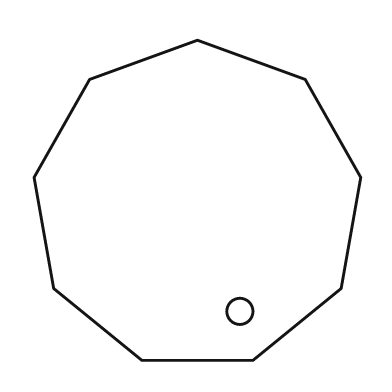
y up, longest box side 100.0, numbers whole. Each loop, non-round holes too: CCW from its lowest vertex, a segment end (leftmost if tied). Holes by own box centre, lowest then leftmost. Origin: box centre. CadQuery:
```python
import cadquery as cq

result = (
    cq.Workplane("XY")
    .moveTo(-17.0, -49.0)
    .lineTo(17.0, -49.0)
    .lineTo(44.0, -27.0)
    .lineTo(50.0, 7.0)
    .lineTo(33.0, 37.0)
    .lineTo(0.0, 49.0)
    .lineTo(-33.0, 37.0)
    .lineTo(-50.0, 7.0)
    .lineTo(-44.0, -27.0)
    .close()
    .moveTo(13.0, -34.0)
    .circle(4.0)
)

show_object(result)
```